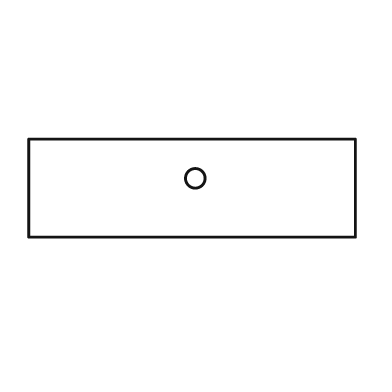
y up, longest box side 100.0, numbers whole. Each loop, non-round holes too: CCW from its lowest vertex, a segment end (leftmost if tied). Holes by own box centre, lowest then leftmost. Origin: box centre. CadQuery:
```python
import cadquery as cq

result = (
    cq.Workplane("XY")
    .moveTo(-50.0, -15.0)
    .lineTo(50.0, -15.0)
    .lineTo(50.0, 15.0)
    .lineTo(-50.0, 15.0)
    .close()
    .moveTo(1.0, 3.0)
    .circle(3.0)
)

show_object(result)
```